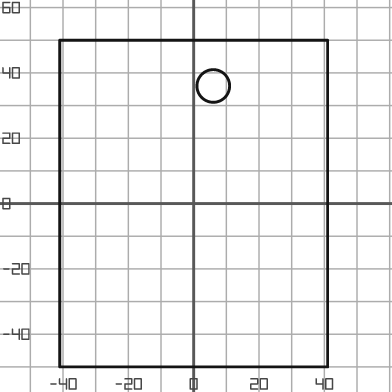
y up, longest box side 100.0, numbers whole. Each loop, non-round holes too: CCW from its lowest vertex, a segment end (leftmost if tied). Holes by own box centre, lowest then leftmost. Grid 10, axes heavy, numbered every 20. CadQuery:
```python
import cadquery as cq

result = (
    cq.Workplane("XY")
    .moveTo(-41.0, -50.0)
    .lineTo(41.0, -50.0)
    .lineTo(41.0, 50.0)
    .lineTo(-41.0, 50.0)
    .close()
    .moveTo(6.0, 36.0)
    .circle(5.0)
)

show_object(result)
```